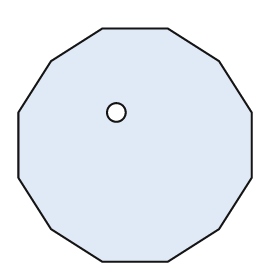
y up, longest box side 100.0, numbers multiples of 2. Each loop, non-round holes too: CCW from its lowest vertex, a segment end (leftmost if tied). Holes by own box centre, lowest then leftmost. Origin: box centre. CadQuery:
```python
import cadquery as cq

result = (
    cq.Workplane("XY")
    .moveTo(-14.0, -50.0)
    .lineTo(14.0, -50.0)
    .lineTo(36.0, -36.0)
    .lineTo(50.0, -14.0)
    .lineTo(50.0, 14.0)
    .lineTo(36.0, 36.0)
    .lineTo(14.0, 50.0)
    .lineTo(-14.0, 50.0)
    .lineTo(-36.0, 36.0)
    .lineTo(-50.0, 14.0)
    .lineTo(-50.0, -14.0)
    .lineTo(-36.0, -36.0)
    .close()
    .moveTo(-8.0, 14.0)
    .circle(4.0)
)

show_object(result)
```